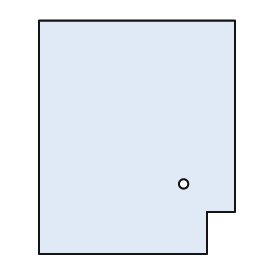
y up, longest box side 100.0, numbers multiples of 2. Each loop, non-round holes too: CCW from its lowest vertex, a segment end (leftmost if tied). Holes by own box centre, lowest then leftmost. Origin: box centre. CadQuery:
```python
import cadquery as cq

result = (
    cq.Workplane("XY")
    .moveTo(-42.0, -50.0)
    .lineTo(30.0, -50.0)
    .lineTo(30.0, -32.0)
    .lineTo(42.0, -32.0)
    .lineTo(42.0, 50.0)
    .lineTo(-42.0, 50.0)
    .close()
    .moveTo(20.0, -20.0)
    .circle(2.0)
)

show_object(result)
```